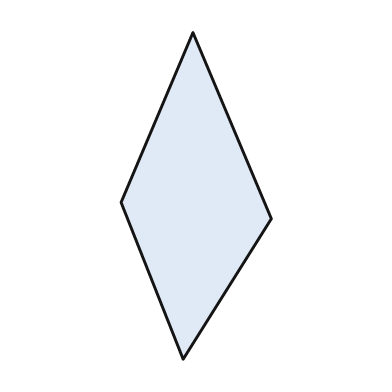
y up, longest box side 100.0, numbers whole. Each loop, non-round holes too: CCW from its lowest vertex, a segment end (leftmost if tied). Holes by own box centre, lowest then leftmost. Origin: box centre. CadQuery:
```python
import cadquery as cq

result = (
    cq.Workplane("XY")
    .moveTo(-4.0, -50.0)
    .lineTo(23.0, -7.0)
    .lineTo(-1.0, 50.0)
    .lineTo(-23.0, -2.0)
    .close()
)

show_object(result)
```